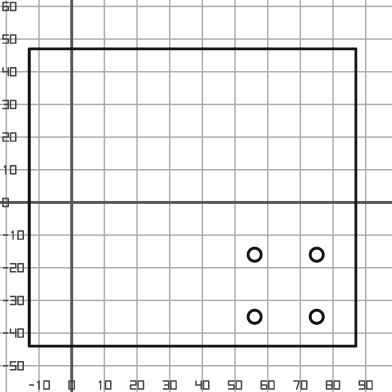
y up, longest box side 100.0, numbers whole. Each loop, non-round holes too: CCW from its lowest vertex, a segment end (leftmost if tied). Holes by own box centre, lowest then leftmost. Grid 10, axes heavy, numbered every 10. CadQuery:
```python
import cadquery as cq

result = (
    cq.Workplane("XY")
    .moveTo(-13.0, -44.0)
    .lineTo(87.0, -44.0)
    .lineTo(87.0, 47.0)
    .lineTo(-13.0, 47.0)
    .close()
    .moveTo(56.0, -35.0)
    .circle(2.0)
    .moveTo(75.0, -35.0)
    .circle(2.0)
    .moveTo(56.0, -16.0)
    .circle(2.0)
    .moveTo(75.0, -16.0)
    .circle(2.0)
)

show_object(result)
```